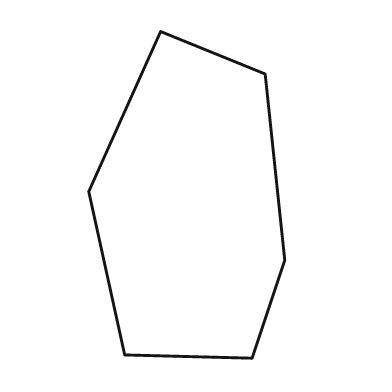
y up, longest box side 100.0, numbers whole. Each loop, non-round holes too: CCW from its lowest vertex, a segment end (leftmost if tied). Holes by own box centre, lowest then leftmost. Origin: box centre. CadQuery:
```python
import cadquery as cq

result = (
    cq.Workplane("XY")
    .moveTo(20.0, -50.0)
    .lineTo(30.0, -20.0)
    .lineTo(24.0, 37.0)
    .lineTo(-8.0, 50.0)
    .lineTo(-30.0, 1.0)
    .lineTo(-19.0, -49.0)
    .close()
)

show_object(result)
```